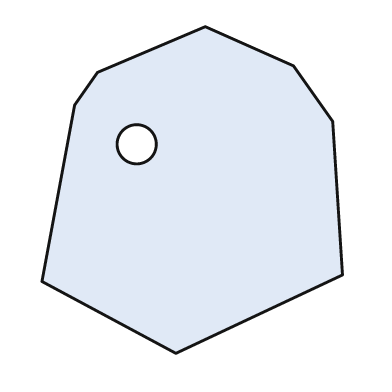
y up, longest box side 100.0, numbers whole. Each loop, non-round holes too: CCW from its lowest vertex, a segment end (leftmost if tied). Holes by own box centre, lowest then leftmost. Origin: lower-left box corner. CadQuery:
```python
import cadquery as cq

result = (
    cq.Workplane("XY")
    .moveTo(41.0, 0.0)
    .lineTo(92.0, 24.0)
    .lineTo(89.0, 71.0)
    .lineTo(77.0, 88.0)
    .lineTo(50.0, 100.0)
    .lineTo(17.0, 86.0)
    .lineTo(10.0, 76.0)
    .lineTo(0.0, 22.0)
    .close()
    .moveTo(29.0, 64.0)
    .circle(6.0)
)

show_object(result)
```